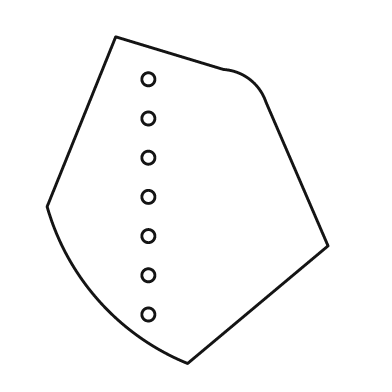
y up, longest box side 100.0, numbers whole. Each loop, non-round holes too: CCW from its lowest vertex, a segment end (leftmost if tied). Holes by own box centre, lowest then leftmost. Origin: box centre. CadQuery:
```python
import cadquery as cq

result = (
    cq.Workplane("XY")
    .moveTo(0.0, -50.0)
    .lineTo(43.0, -14.0)
    .lineTo(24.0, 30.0)
    .threePointArc((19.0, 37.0), (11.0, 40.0))
    .lineTo(-22.0, 50.0)
    .lineTo(-43.0, -2.0)
    .threePointArc((-27.0, -31.0), (0.0, -50.0))
    .close()
    .moveTo(-12.0, -35.0)
    .circle(2.0)
    .moveTo(-12.0, -23.0)
    .circle(2.0)
    .moveTo(-12.0, -11.0)
    .circle(2.0)
    .moveTo(-12.0, 1.0)
    .circle(2.0)
    .moveTo(-12.0, 13.0)
    .circle(2.0)
    .moveTo(-12.0, 25.0)
    .circle(2.0)
    .moveTo(-12.0, 37.0)
    .circle(2.0)
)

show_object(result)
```